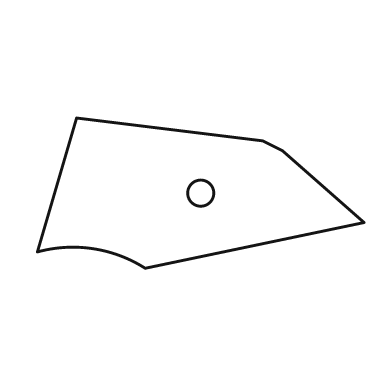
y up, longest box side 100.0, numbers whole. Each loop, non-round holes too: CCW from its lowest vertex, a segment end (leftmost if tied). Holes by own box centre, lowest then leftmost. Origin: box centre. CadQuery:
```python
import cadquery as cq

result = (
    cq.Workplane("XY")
    .moveTo(-17.0, -23.0)
    .lineTo(50.0, -9.0)
    .lineTo(25.0, 13.0)
    .lineTo(19.0, 16.0)
    .lineTo(-38.0, 23.0)
    .lineTo(-50.0, -18.0)
    .threePointArc((-33.0, -17.0), (-17.0, -23.0))
    .close()
    .moveTo(0.0, 0.0)
    .circle(4.0)
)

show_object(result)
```